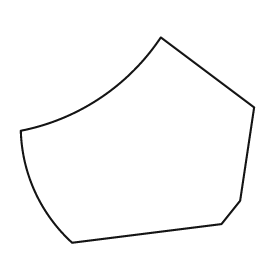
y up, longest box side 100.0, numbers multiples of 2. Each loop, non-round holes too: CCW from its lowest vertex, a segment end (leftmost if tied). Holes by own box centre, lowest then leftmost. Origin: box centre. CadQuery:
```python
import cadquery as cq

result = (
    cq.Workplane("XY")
    .moveTo(-28.0, -44.0)
    .lineTo(36.0, -36.0)
    .lineTo(44.0, -26.0)
    .lineTo(50.0, 14.0)
    .lineTo(10.0, 44.0)
    .threePointArc((-16.0, 18.0), (-50.0, 4.0))
    .threePointArc((-44.0, -22.0), (-28.0, -44.0))
    .close()
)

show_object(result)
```